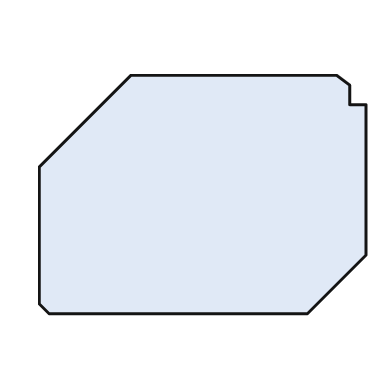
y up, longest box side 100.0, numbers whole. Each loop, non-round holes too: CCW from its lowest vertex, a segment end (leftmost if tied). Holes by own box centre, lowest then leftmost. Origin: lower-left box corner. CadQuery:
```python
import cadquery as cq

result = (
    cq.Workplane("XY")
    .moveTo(3.0, 0.0)
    .lineTo(82.0, 0.0)
    .lineTo(100.0, 18.0)
    .lineTo(100.0, 64.0)
    .lineTo(95.0, 64.0)
    .lineTo(95.0, 70.0)
    .lineTo(91.0, 73.0)
    .lineTo(28.0, 73.0)
    .lineTo(0.0, 45.0)
    .lineTo(0.0, 3.0)
    .close()
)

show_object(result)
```